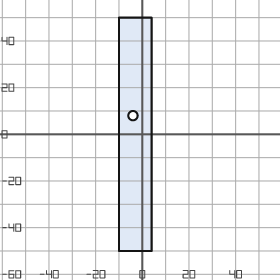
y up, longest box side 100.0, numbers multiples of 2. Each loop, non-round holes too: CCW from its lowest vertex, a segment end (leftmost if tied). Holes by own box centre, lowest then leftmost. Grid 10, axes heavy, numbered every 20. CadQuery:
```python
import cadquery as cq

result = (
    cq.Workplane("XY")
    .moveTo(-10.0, -50.0)
    .lineTo(4.0, -50.0)
    .lineTo(4.0, 50.0)
    .lineTo(-10.0, 50.0)
    .close()
    .moveTo(-4.0, 8.0)
    .circle(2.0)
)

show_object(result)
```